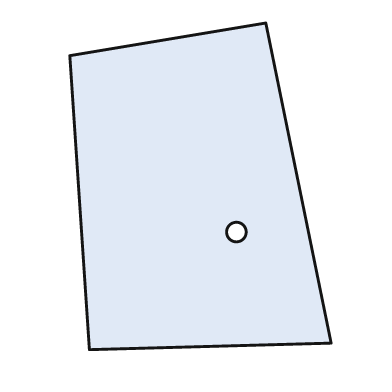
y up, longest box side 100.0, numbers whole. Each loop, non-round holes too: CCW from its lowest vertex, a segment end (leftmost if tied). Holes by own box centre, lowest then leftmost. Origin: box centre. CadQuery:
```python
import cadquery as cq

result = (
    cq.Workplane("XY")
    .moveTo(-34.0, -50.0)
    .lineTo(40.0, -48.0)
    .lineTo(20.0, 50.0)
    .lineTo(-40.0, 40.0)
    .close()
    .moveTo(11.0, -14.0)
    .circle(3.0)
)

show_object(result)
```